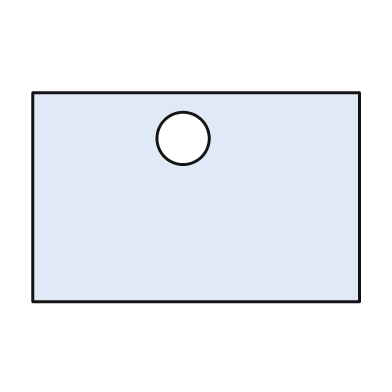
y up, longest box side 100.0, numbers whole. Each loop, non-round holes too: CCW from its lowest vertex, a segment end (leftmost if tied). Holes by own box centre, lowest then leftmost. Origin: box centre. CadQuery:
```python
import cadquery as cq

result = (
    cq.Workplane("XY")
    .moveTo(-50.0, -32.0)
    .lineTo(50.0, -32.0)
    .lineTo(50.0, 32.0)
    .lineTo(-50.0, 32.0)
    .close()
    .moveTo(-4.0, 18.0)
    .circle(8.0)
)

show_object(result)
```